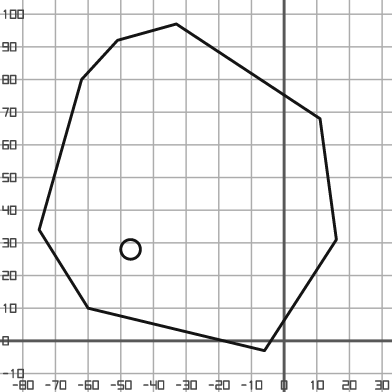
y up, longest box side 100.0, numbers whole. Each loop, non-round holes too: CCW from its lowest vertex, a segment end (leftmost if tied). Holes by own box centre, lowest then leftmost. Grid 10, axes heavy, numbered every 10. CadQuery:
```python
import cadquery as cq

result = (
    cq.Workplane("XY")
    .moveTo(-6.0, -3.0)
    .lineTo(16.0, 31.0)
    .lineTo(11.0, 68.0)
    .lineTo(-33.0, 97.0)
    .lineTo(-51.0, 92.0)
    .lineTo(-62.0, 80.0)
    .lineTo(-75.0, 34.0)
    .lineTo(-60.0, 10.0)
    .close()
    .moveTo(-47.0, 28.0)
    .circle(3.0)
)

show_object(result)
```